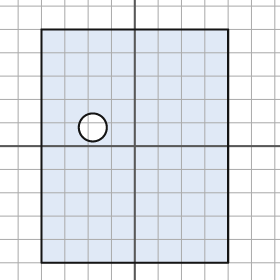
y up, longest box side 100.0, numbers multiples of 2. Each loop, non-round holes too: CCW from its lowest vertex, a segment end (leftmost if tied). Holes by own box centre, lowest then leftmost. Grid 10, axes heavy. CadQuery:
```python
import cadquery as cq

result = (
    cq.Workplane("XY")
    .moveTo(-40.0, -50.0)
    .lineTo(40.0, -50.0)
    .lineTo(40.0, 50.0)
    .lineTo(-40.0, 50.0)
    .close()
    .moveTo(-18.0, 8.0)
    .circle(6.0)
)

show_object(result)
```